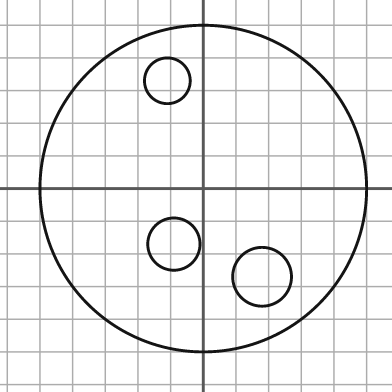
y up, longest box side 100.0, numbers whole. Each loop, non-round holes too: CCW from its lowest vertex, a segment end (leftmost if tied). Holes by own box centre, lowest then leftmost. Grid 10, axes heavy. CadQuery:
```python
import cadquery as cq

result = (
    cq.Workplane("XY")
    .moveTo(0.0, 0.0)
    .circle(50.0)
    .moveTo(18.0, -27.0)
    .circle(9.0)
    .moveTo(-9.0, -17.0)
    .circle(8.0)
    .moveTo(-11.0, 33.0)
    .circle(7.0)
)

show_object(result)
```